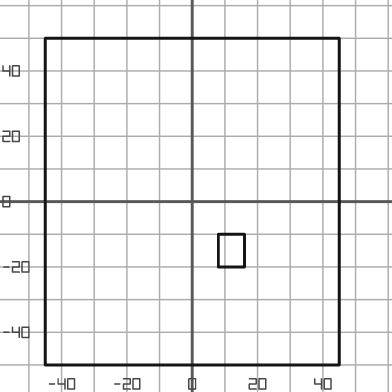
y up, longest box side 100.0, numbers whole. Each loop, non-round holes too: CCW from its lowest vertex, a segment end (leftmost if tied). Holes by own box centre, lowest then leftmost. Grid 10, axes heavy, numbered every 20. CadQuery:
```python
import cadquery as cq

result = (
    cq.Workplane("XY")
    .moveTo(-45.0, -50.0)
    .lineTo(45.0, -50.0)
    .lineTo(45.0, 50.0)
    .lineTo(-45.0, 50.0)
    .close()
    .moveTo(8.0, -20.0)
    .lineTo(16.0, -20.0)
    .lineTo(16.0, -10.0)
    .lineTo(8.0, -10.0)
    .close()
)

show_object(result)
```